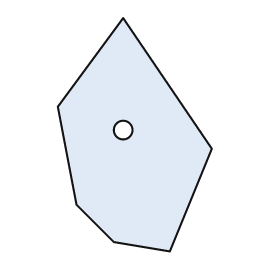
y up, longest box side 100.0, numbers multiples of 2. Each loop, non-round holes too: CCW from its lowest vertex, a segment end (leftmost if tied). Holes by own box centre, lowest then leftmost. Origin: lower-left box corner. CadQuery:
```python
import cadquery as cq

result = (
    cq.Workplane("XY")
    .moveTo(48.0, 0.0)
    .lineTo(66.0, 44.0)
    .lineTo(28.0, 100.0)
    .lineTo(0.0, 62.0)
    .lineTo(8.0, 20.0)
    .lineTo(24.0, 4.0)
    .close()
    .moveTo(28.0, 52.0)
    .circle(4.0)
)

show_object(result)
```